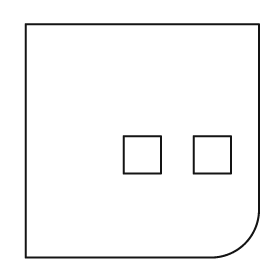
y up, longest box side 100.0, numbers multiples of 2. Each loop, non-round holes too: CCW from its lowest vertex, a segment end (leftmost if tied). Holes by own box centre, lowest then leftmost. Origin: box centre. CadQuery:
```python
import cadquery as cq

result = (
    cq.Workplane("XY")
    .moveTo(-50.0, -50.0)
    .lineTo(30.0, -50.0)
    .threePointArc((44.0, -44.0), (50.0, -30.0))
    .lineTo(50.0, 50.0)
    .lineTo(-50.0, 50.0)
    .close()
    .moveTo(-8.0, -14.0)
    .lineTo(8.0, -14.0)
    .lineTo(8.0, 2.0)
    .lineTo(-8.0, 2.0)
    .close()
    .moveTo(22.0, -14.0)
    .lineTo(38.0, -14.0)
    .lineTo(38.0, 2.0)
    .lineTo(22.0, 2.0)
    .close()
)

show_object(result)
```